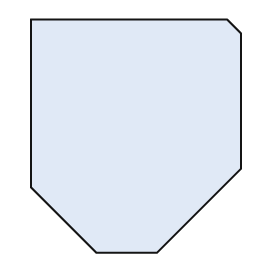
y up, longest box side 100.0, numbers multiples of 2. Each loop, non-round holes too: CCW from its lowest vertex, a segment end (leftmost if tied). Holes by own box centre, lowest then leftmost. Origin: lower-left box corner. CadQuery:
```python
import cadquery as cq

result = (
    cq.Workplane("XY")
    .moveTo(28.0, 0.0)
    .lineTo(54.0, 0.0)
    .lineTo(90.0, 36.0)
    .lineTo(90.0, 94.0)
    .lineTo(84.0, 100.0)
    .lineTo(0.0, 100.0)
    .lineTo(0.0, 28.0)
    .close()
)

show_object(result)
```